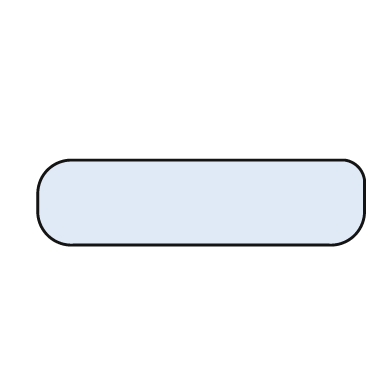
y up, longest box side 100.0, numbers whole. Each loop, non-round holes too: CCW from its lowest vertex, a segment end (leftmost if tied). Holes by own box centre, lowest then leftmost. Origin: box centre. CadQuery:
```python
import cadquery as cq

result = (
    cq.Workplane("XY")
    .moveTo(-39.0, -13.0)
    .lineTo(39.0, -13.0)
    .threePointArc((47.0, -10.0), (50.0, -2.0))
    .lineTo(50.0, 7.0)
    .threePointArc((48.0, 11.0), (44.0, 13.0))
    .lineTo(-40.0, 13.0)
    .threePointArc((-47.0, 10.0), (-50.0, 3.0))
    .lineTo(-50.0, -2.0)
    .threePointArc((-47.0, -10.0), (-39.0, -13.0))
    .close()
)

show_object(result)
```